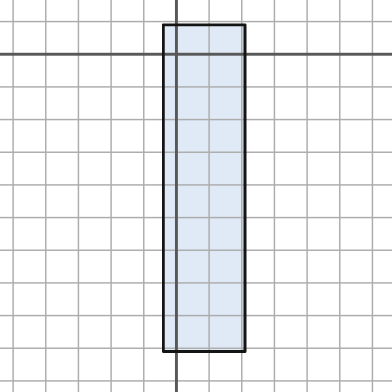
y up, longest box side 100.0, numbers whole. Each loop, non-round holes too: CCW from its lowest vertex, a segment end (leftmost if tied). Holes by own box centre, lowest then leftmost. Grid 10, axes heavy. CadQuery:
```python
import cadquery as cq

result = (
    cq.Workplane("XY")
    .moveTo(-4.0, -91.0)
    .lineTo(21.0, -91.0)
    .lineTo(21.0, 9.0)
    .lineTo(-4.0, 9.0)
    .close()
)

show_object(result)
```